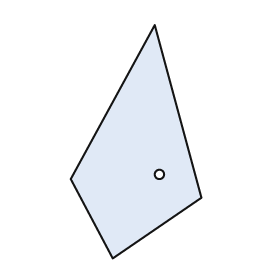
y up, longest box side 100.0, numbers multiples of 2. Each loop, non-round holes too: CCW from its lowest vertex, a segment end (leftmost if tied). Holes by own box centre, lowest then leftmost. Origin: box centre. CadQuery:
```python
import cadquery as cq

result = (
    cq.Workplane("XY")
    .moveTo(-10.0, -50.0)
    .lineTo(28.0, -24.0)
    .lineTo(8.0, 50.0)
    .lineTo(-28.0, -16.0)
    .close()
    .moveTo(10.0, -14.0)
    .circle(2.0)
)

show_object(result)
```